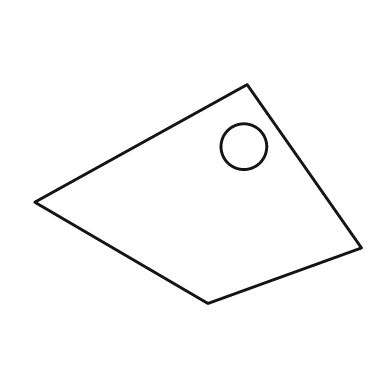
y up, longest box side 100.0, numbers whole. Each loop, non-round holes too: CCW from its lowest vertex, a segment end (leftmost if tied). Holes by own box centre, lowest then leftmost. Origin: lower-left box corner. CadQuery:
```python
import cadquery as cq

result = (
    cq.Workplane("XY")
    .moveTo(53.0, 0.0)
    .lineTo(100.0, 17.0)
    .lineTo(65.0, 67.0)
    .lineTo(0.0, 31.0)
    .close()
    .moveTo(64.0, 48.0)
    .circle(7.0)
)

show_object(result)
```